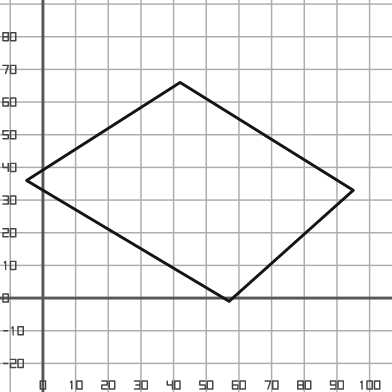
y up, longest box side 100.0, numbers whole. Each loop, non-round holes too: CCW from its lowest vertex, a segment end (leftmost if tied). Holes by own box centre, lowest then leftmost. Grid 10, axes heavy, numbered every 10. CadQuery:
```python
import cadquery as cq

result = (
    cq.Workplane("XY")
    .moveTo(57.0, -1.0)
    .lineTo(95.0, 33.0)
    .lineTo(42.0, 66.0)
    .lineTo(-5.0, 36.0)
    .close()
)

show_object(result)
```